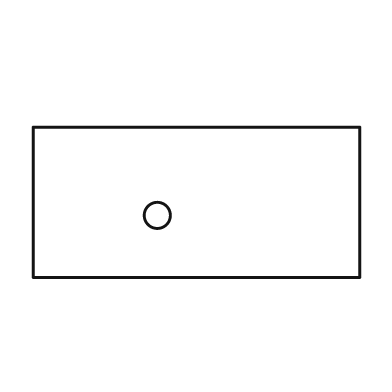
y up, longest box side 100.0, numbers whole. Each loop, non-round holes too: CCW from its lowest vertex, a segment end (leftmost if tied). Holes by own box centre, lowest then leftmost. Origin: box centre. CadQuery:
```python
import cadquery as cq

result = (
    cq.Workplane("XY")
    .moveTo(-50.0, -23.0)
    .lineTo(50.0, -23.0)
    .lineTo(50.0, 23.0)
    .lineTo(-50.0, 23.0)
    .close()
    .moveTo(-12.0, -4.0)
    .circle(4.0)
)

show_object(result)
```